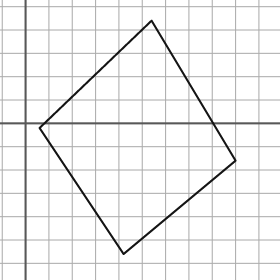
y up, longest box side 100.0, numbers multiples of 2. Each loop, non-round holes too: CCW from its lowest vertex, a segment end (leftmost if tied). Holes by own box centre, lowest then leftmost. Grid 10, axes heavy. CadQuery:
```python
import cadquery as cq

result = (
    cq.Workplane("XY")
    .moveTo(42.0, -56.0)
    .lineTo(90.0, -16.0)
    .lineTo(54.0, 44.0)
    .lineTo(6.0, -2.0)
    .close()
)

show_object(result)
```